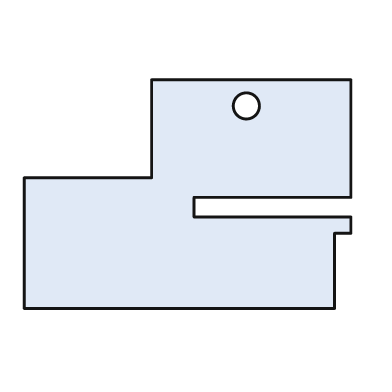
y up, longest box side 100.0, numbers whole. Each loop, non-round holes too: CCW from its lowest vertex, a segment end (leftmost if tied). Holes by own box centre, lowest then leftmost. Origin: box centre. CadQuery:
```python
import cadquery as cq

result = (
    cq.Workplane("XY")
    .moveTo(-50.0, -35.0)
    .lineTo(45.0, -35.0)
    .lineTo(45.0, -12.0)
    .lineTo(50.0, -12.0)
    .lineTo(50.0, -7.0)
    .lineTo(2.0, -7.0)
    .lineTo(2.0, -1.0)
    .lineTo(50.0, -1.0)
    .lineTo(50.0, 35.0)
    .lineTo(-11.0, 35.0)
    .lineTo(-11.0, 5.0)
    .lineTo(-50.0, 5.0)
    .close()
    .moveTo(18.0, 27.0)
    .circle(4.0)
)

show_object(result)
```